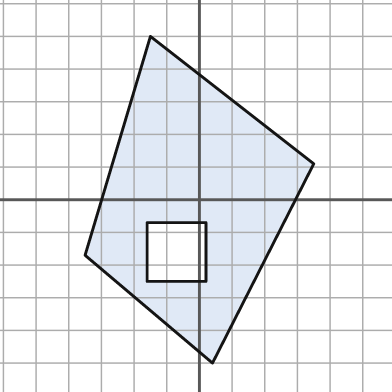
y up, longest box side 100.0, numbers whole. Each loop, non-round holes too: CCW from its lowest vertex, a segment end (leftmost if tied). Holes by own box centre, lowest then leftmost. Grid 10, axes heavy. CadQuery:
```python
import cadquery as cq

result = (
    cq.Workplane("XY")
    .moveTo(4.0, -50.0)
    .lineTo(35.0, 11.0)
    .lineTo(-15.0, 50.0)
    .lineTo(-35.0, -17.0)
    .close()
    .moveTo(-16.0, -25.0)
    .lineTo(2.0, -25.0)
    .lineTo(2.0, -7.0)
    .lineTo(-16.0, -7.0)
    .close()
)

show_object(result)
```